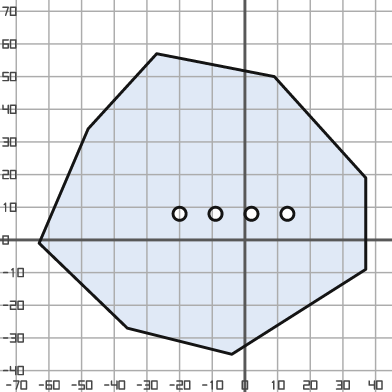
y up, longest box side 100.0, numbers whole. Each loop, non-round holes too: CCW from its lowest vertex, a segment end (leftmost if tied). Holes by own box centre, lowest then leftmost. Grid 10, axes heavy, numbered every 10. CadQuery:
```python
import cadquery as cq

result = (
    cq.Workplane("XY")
    .moveTo(-4.0, -35.0)
    .lineTo(37.0, -9.0)
    .lineTo(37.0, 19.0)
    .lineTo(9.0, 50.0)
    .lineTo(-27.0, 57.0)
    .lineTo(-48.0, 34.0)
    .lineTo(-63.0, -1.0)
    .lineTo(-36.0, -27.0)
    .close()
    .moveTo(-20.0, 8.0)
    .circle(2.0)
    .moveTo(-9.0, 8.0)
    .circle(2.0)
    .moveTo(2.0, 8.0)
    .circle(2.0)
    .moveTo(13.0, 8.0)
    .circle(2.0)
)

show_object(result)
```